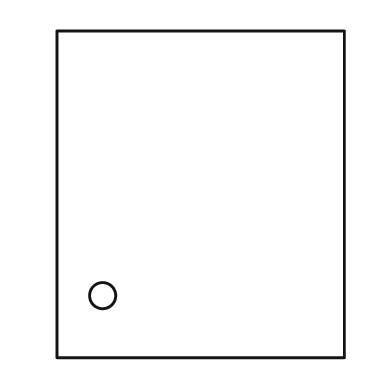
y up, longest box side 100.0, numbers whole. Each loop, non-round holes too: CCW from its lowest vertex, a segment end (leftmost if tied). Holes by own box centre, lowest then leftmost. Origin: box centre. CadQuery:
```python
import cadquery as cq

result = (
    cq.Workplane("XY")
    .moveTo(-44.0, -50.0)
    .lineTo(44.0, -50.0)
    .lineTo(44.0, 50.0)
    .lineTo(-44.0, 50.0)
    .close()
    .moveTo(-30.0, -31.0)
    .circle(4.0)
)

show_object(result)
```